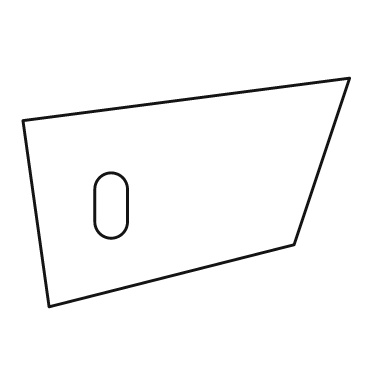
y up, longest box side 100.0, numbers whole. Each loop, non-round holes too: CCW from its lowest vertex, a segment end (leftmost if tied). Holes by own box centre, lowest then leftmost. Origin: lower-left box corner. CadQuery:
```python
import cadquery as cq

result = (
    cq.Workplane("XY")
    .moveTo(8.0, 0.0)
    .lineTo(83.0, 19.0)
    .lineTo(100.0, 70.0)
    .lineTo(0.0, 57.0)
    .close()
    .moveTo(22.0, 26.0)
    .threePointArc((27.0, 21.0), (32.0, 26.0))
    .lineTo(32.0, 36.0)
    .threePointArc((27.0, 41.0), (22.0, 36.0))
    .close()
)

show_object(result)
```